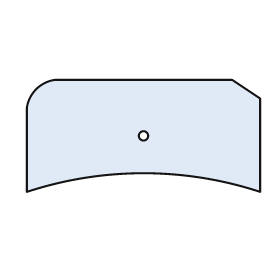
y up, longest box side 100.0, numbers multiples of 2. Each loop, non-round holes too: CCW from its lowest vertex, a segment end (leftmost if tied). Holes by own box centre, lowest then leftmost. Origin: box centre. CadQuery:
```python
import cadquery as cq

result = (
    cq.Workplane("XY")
    .moveTo(-50.0, -24.0)
    .threePointArc((0.0, -16.0), (50.0, -24.0))
    .lineTo(50.0, 16.0)
    .lineTo(38.0, 24.0)
    .lineTo(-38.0, 24.0)
    .threePointArc((-46.0, 20.0), (-50.0, 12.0))
    .close()
    .moveTo(0.0, 0.0)
    .circle(2.0)
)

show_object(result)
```